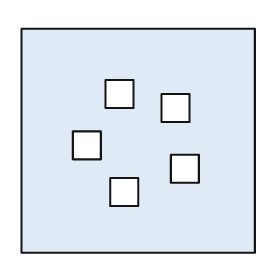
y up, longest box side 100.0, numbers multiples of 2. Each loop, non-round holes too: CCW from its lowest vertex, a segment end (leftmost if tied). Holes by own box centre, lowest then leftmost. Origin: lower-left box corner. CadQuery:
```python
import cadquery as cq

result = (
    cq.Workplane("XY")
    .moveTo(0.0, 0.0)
    .lineTo(100.0, 0.0)
    .lineTo(100.0, 96.0)
    .lineTo(0.0, 96.0)
    .close()
    .moveTo(38.0, 20.0)
    .lineTo(50.0, 20.0)
    .lineTo(50.0, 32.0)
    .lineTo(38.0, 32.0)
    .close()
    .moveTo(64.0, 30.0)
    .lineTo(76.0, 30.0)
    .lineTo(76.0, 42.0)
    .lineTo(64.0, 42.0)
    .close()
    .moveTo(22.0, 40.0)
    .lineTo(34.0, 40.0)
    .lineTo(34.0, 52.0)
    .lineTo(22.0, 52.0)
    .close()
    .moveTo(60.0, 56.0)
    .lineTo(72.0, 56.0)
    .lineTo(72.0, 68.0)
    .lineTo(60.0, 68.0)
    .close()
    .moveTo(36.0, 62.0)
    .lineTo(48.0, 62.0)
    .lineTo(48.0, 74.0)
    .lineTo(36.0, 74.0)
    .close()
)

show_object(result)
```